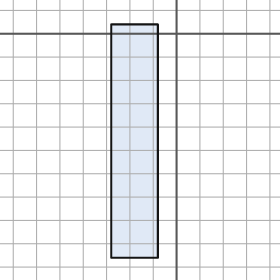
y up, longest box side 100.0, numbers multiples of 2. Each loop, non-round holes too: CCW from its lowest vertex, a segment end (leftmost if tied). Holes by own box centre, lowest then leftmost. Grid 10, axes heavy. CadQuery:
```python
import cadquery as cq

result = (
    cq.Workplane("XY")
    .moveTo(-28.0, -96.0)
    .lineTo(-8.0, -96.0)
    .lineTo(-8.0, 4.0)
    .lineTo(-28.0, 4.0)
    .close()
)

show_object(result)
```